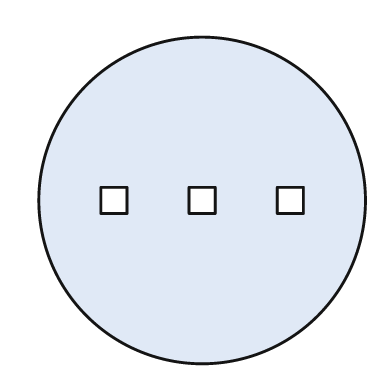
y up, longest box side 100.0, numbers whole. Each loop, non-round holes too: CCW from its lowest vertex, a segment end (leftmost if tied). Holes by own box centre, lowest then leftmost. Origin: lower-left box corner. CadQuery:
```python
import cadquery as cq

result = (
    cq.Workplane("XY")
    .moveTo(50.0, 50.0)
    .circle(50.0)
    .moveTo(19.0, 46.0)
    .lineTo(27.0, 46.0)
    .lineTo(27.0, 54.0)
    .lineTo(19.0, 54.0)
    .close()
    .moveTo(46.0, 46.0)
    .lineTo(54.0, 46.0)
    .lineTo(54.0, 54.0)
    .lineTo(46.0, 54.0)
    .close()
    .moveTo(73.0, 46.0)
    .lineTo(81.0, 46.0)
    .lineTo(81.0, 54.0)
    .lineTo(73.0, 54.0)
    .close()
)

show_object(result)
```